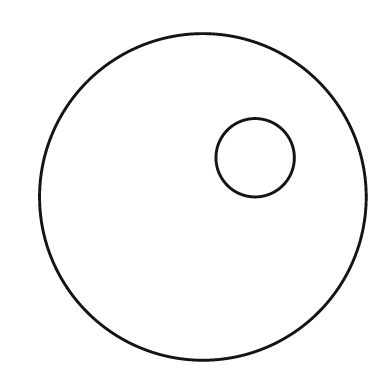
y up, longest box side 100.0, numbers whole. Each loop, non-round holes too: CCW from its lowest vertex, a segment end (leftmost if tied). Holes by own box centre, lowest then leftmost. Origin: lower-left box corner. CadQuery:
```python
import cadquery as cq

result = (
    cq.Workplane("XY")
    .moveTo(50.0, 50.0)
    .circle(50.0)
    .moveTo(66.0, 62.0)
    .circle(12.0)
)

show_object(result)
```